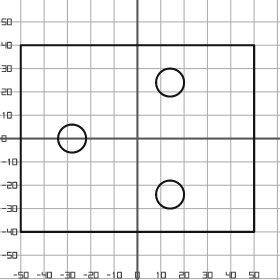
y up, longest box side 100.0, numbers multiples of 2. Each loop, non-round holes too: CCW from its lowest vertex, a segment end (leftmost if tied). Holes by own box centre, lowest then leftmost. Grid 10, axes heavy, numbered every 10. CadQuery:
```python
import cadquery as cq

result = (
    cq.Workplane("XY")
    .moveTo(-50.0, -40.0)
    .lineTo(50.0, -40.0)
    .lineTo(50.0, 40.0)
    .lineTo(-50.0, 40.0)
    .close()
    .moveTo(14.0, -24.0)
    .circle(6.0)
    .moveTo(-28.0, 0.0)
    .circle(6.0)
    .moveTo(14.0, 24.0)
    .circle(6.0)
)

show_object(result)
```